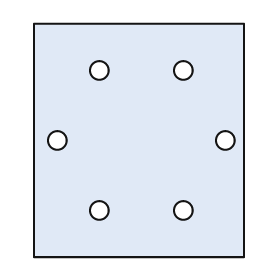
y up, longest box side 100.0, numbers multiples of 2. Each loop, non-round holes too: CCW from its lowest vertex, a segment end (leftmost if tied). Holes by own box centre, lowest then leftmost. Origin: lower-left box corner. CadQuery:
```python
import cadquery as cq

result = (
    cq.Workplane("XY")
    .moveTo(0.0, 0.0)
    .lineTo(90.0, 0.0)
    .lineTo(90.0, 100.0)
    .lineTo(0.0, 100.0)
    .close()
    .moveTo(28.0, 20.0)
    .circle(4.0)
    .moveTo(64.0, 20.0)
    .circle(4.0)
    .moveTo(10.0, 50.0)
    .circle(4.0)
    .moveTo(82.0, 50.0)
    .circle(4.0)
    .moveTo(28.0, 80.0)
    .circle(4.0)
    .moveTo(64.0, 80.0)
    .circle(4.0)
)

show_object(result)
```